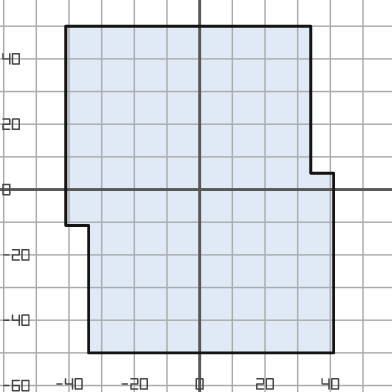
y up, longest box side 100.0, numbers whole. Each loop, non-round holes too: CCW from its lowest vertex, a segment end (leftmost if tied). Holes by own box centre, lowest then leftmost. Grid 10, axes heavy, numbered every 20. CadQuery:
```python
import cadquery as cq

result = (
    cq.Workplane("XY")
    .moveTo(-34.0, -50.0)
    .lineTo(41.0, -50.0)
    .lineTo(41.0, 5.0)
    .lineTo(34.0, 5.0)
    .lineTo(34.0, 50.0)
    .lineTo(-41.0, 50.0)
    .lineTo(-41.0, -11.0)
    .lineTo(-34.0, -11.0)
    .close()
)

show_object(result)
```